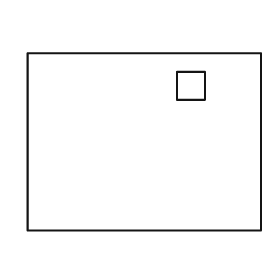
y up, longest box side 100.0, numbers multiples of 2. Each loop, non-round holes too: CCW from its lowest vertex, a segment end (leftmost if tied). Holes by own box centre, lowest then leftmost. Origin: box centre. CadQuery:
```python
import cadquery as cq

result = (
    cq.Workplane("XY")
    .moveTo(-50.0, -38.0)
    .lineTo(50.0, -38.0)
    .lineTo(50.0, 38.0)
    .lineTo(-50.0, 38.0)
    .close()
    .moveTo(14.0, 18.0)
    .lineTo(26.0, 18.0)
    .lineTo(26.0, 30.0)
    .lineTo(14.0, 30.0)
    .close()
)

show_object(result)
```